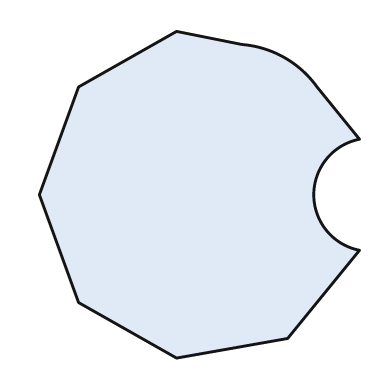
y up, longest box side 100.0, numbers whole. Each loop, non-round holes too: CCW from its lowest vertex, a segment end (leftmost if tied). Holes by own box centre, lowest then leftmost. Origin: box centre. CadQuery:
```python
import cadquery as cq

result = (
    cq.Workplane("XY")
    .moveTo(-7.0, -50.0)
    .lineTo(27.0, -44.0)
    .lineTo(49.0, -17.0)
    .threePointArc((35.0, 0.0), (49.0, 17.0))
    .lineTo(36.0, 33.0)
    .threePointArc((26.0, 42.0), (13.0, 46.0))
    .lineTo(-7.0, 50.0)
    .lineTo(-37.0, 33.0)
    .lineTo(-49.0, 0.0)
    .lineTo(-37.0, -33.0)
    .close()
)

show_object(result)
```